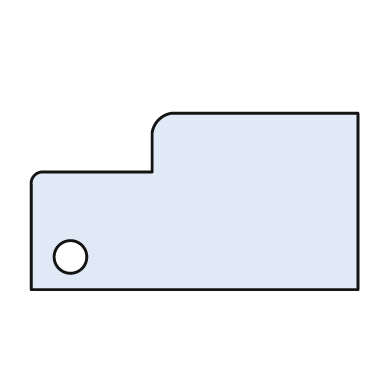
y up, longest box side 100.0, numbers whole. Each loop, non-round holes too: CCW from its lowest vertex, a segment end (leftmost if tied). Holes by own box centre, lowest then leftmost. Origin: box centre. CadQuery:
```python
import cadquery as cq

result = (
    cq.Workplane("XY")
    .moveTo(-50.0, -27.0)
    .lineTo(50.0, -27.0)
    .lineTo(50.0, 27.0)
    .lineTo(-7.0, 27.0)
    .threePointArc((-11.0, 25.0), (-13.0, 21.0))
    .lineTo(-13.0, 9.0)
    .lineTo(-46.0, 9.0)
    .threePointArc((-49.0, 8.0), (-50.0, 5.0))
    .close()
    .moveTo(-38.0, -17.0)
    .circle(5.0)
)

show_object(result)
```